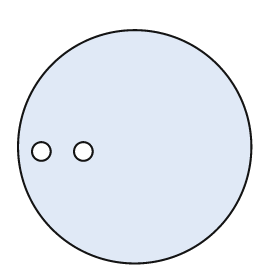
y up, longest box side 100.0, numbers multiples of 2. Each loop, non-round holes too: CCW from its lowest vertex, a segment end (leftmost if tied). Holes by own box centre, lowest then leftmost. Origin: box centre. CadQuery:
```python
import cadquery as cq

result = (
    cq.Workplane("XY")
    .moveTo(0.0, 0.0)
    .circle(50.0)
    .moveTo(-40.0, -2.0)
    .circle(4.0)
    .moveTo(-22.0, -2.0)
    .circle(4.0)
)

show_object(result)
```